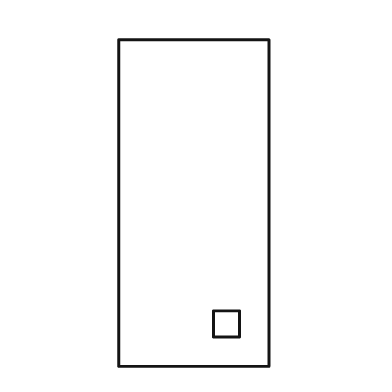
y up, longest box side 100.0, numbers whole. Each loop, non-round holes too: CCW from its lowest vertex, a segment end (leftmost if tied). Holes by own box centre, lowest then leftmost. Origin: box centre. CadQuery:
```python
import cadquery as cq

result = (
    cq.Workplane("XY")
    .moveTo(-23.0, -50.0)
    .lineTo(23.0, -50.0)
    .lineTo(23.0, 50.0)
    .lineTo(-23.0, 50.0)
    .close()
    .moveTo(6.0, -41.0)
    .lineTo(14.0, -41.0)
    .lineTo(14.0, -33.0)
    .lineTo(6.0, -33.0)
    .close()
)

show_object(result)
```